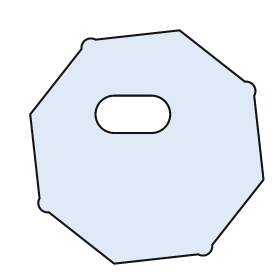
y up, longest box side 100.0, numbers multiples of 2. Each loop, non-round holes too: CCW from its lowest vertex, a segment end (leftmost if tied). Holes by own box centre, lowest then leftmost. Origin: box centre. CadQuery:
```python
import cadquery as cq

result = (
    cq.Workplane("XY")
    .moveTo(-14.0, -50.0)
    .lineTo(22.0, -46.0)
    .threePointArc((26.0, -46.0), (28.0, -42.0))
    .lineTo(50.0, -14.0)
    .lineTo(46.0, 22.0)
    .threePointArc((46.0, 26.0), (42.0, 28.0))
    .lineTo(14.0, 50.0)
    .lineTo(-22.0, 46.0)
    .threePointArc((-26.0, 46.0), (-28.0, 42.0))
    .lineTo(-50.0, 14.0)
    .lineTo(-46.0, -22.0)
    .threePointArc((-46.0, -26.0), (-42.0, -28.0))
    .close()
    .moveTo(-14.0, 6.0)
    .lineTo(2.0, 6.0)
    .threePointArc((10.0, 14.0), (2.0, 22.0))
    .lineTo(-14.0, 22.0)
    .threePointArc((-22.0, 14.0), (-14.0, 6.0))
    .close()
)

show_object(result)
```